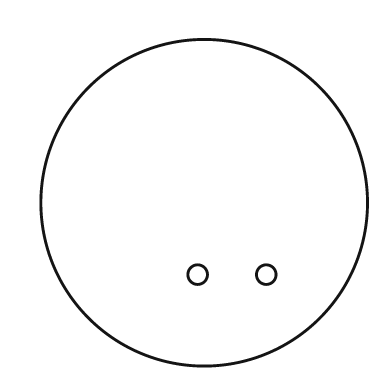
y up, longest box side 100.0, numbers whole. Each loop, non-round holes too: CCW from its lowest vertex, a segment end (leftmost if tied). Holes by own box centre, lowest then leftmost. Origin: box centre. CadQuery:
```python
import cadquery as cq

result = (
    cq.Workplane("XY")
    .moveTo(0.0, 0.0)
    .circle(50.0)
    .moveTo(-2.0, -22.0)
    .circle(3.0)
    .moveTo(19.0, -22.0)
    .circle(3.0)
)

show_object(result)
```